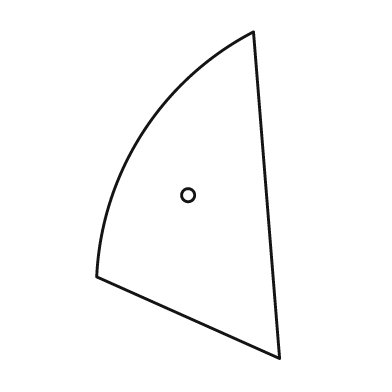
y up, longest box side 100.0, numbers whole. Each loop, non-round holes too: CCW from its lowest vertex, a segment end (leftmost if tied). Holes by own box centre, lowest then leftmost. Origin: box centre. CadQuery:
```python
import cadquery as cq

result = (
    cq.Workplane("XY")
    .moveTo(28.0, -50.0)
    .lineTo(20.0, 50.0)
    .threePointArc((-14.0, 19.0), (-28.0, -25.0))
    .close()
    .moveTo(0.0, 0.0)
    .circle(2.0)
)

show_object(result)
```